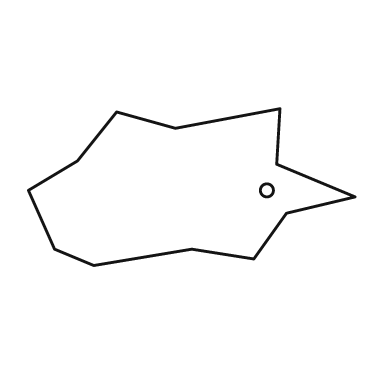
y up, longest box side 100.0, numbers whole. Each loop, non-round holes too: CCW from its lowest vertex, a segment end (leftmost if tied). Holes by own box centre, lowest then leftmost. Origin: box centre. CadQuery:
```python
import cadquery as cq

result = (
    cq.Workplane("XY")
    .moveTo(-30.0, -24.0)
    .lineTo(0.0, -19.0)
    .lineTo(19.0, -22.0)
    .lineTo(29.0, -8.0)
    .lineTo(50.0, -3.0)
    .lineTo(26.0, 7.0)
    .lineTo(27.0, 24.0)
    .lineTo(-5.0, 18.0)
    .lineTo(-23.0, 23.0)
    .lineTo(-35.0, 8.0)
    .lineTo(-50.0, -1.0)
    .lineTo(-42.0, -19.0)
    .close()
    .moveTo(23.0, -1.0)
    .circle(2.0)
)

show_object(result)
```